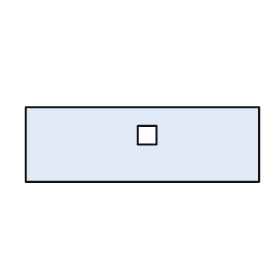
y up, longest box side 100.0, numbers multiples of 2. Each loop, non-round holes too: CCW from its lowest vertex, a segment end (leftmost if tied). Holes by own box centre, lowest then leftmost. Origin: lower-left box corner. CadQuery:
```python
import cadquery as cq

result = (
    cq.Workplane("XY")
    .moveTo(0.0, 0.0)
    .lineTo(100.0, 0.0)
    .lineTo(100.0, 32.0)
    .lineTo(0.0, 32.0)
    .close()
    .moveTo(48.0, 16.0)
    .lineTo(56.0, 16.0)
    .lineTo(56.0, 24.0)
    .lineTo(48.0, 24.0)
    .close()
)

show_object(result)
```